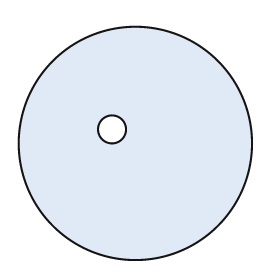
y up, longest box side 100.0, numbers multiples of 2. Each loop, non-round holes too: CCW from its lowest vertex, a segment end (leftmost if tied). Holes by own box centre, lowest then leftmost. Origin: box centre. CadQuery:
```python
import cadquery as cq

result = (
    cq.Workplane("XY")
    .moveTo(0.0, 0.0)
    .circle(50.0)
    .moveTo(-10.0, 6.0)
    .circle(6.0)
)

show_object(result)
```